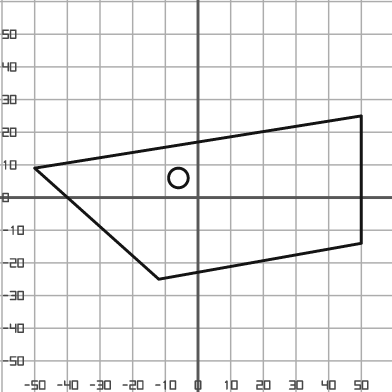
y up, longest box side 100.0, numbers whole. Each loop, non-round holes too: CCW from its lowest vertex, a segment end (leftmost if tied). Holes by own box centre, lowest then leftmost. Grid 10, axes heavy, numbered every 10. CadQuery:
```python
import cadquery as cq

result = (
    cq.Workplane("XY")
    .moveTo(-12.0, -25.0)
    .lineTo(50.0, -14.0)
    .lineTo(50.0, 25.0)
    .lineTo(-50.0, 9.0)
    .close()
    .moveTo(-6.0, 6.0)
    .circle(3.0)
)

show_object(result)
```